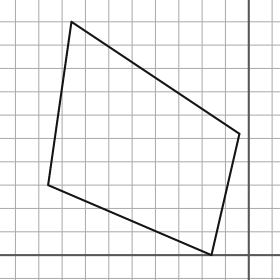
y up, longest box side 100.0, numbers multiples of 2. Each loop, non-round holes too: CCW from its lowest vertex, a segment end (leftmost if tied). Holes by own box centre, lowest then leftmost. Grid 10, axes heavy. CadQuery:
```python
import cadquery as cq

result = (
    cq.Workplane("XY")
    .moveTo(-16.0, 0.0)
    .lineTo(-4.0, 52.0)
    .lineTo(-76.0, 100.0)
    .lineTo(-86.0, 30.0)
    .close()
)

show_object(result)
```